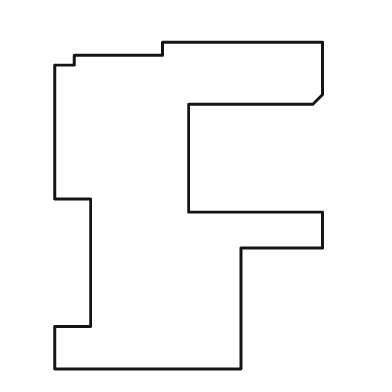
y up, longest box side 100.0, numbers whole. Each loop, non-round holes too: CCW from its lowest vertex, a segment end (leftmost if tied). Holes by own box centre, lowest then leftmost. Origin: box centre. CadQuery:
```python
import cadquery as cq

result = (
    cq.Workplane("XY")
    .moveTo(-41.0, -50.0)
    .lineTo(16.0, -50.0)
    .lineTo(16.0, -13.0)
    .lineTo(41.0, -13.0)
    .lineTo(41.0, -2.0)
    .lineTo(0.0, -2.0)
    .lineTo(0.0, 31.0)
    .lineTo(38.0, 31.0)
    .lineTo(41.0, 34.0)
    .lineTo(41.0, 50.0)
    .lineTo(-8.0, 50.0)
    .lineTo(-8.0, 46.0)
    .lineTo(-35.0, 46.0)
    .lineTo(-35.0, 43.0)
    .lineTo(-41.0, 43.0)
    .lineTo(-41.0, 2.0)
    .lineTo(-30.0, 2.0)
    .lineTo(-30.0, -37.0)
    .lineTo(-41.0, -37.0)
    .close()
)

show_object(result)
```